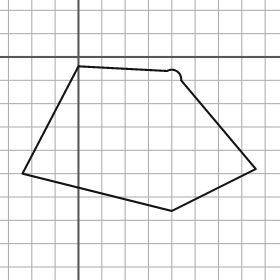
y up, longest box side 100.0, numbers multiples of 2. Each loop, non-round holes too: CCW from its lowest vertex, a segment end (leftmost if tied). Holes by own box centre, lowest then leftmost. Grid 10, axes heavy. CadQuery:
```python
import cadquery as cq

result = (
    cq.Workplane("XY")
    .moveTo(40.0, -66.0)
    .lineTo(76.0, -48.0)
    .lineTo(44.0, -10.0)
    .threePointArc((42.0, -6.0), (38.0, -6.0))
    .lineTo(0.0, -4.0)
    .lineTo(-24.0, -50.0)
    .close()
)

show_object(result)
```